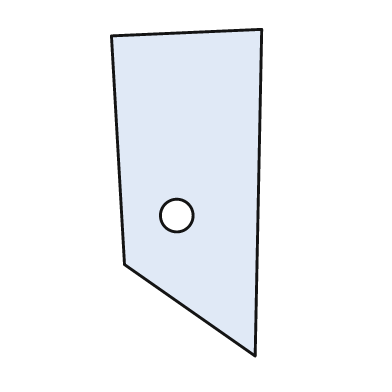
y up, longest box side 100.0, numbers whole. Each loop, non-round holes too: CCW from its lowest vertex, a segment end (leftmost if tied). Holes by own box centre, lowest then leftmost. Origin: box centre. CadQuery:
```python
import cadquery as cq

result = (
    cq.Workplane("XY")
    .moveTo(21.0, -50.0)
    .lineTo(23.0, 50.0)
    .lineTo(-23.0, 48.0)
    .lineTo(-19.0, -22.0)
    .close()
    .moveTo(-3.0, -7.0)
    .circle(5.0)
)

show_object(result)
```